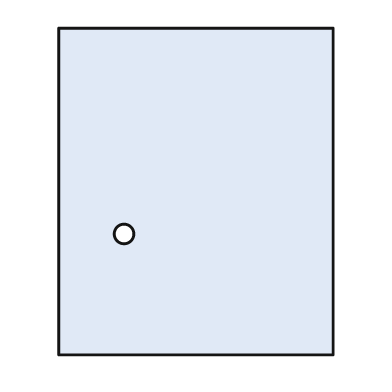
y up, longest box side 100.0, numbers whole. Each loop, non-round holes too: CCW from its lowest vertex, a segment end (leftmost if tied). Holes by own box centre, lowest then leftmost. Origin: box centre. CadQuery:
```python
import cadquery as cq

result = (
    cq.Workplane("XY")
    .moveTo(-42.0, -50.0)
    .lineTo(42.0, -50.0)
    .lineTo(42.0, 50.0)
    .lineTo(-42.0, 50.0)
    .close()
    .moveTo(-22.0, -13.0)
    .circle(3.0)
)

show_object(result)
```